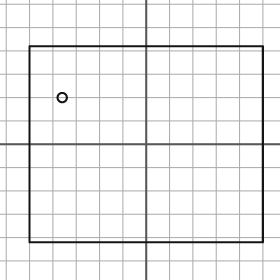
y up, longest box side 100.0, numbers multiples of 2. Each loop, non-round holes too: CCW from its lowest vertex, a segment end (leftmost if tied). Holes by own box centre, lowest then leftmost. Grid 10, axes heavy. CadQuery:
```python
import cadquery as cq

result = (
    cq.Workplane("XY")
    .moveTo(-50.0, -42.0)
    .lineTo(50.0, -42.0)
    .lineTo(50.0, 42.0)
    .lineTo(-50.0, 42.0)
    .close()
    .moveTo(-36.0, 20.0)
    .circle(2.0)
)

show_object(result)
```